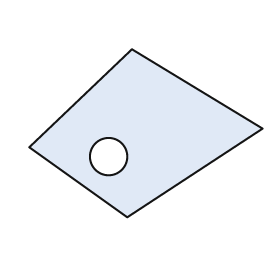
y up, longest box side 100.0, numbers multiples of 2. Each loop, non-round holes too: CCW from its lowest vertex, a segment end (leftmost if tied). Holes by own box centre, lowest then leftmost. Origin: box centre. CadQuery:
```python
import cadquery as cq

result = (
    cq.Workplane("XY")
    .moveTo(-8.0, -36.0)
    .lineTo(50.0, 2.0)
    .lineTo(-6.0, 36.0)
    .lineTo(-50.0, -6.0)
    .close()
    .moveTo(-16.0, -10.0)
    .circle(8.0)
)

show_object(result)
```